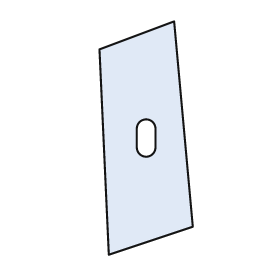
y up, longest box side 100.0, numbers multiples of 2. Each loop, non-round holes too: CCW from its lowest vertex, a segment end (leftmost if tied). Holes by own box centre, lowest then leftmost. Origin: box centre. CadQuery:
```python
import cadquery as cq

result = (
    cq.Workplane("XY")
    .moveTo(-16.0, -50.0)
    .lineTo(20.0, -38.0)
    .lineTo(12.0, 50.0)
    .lineTo(-20.0, 38.0)
    .close()
    .moveTo(-4.0, -4.0)
    .threePointArc((0.0, -8.0), (4.0, -4.0))
    .lineTo(4.0, 4.0)
    .threePointArc((0.0, 8.0), (-4.0, 4.0))
    .close()
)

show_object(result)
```